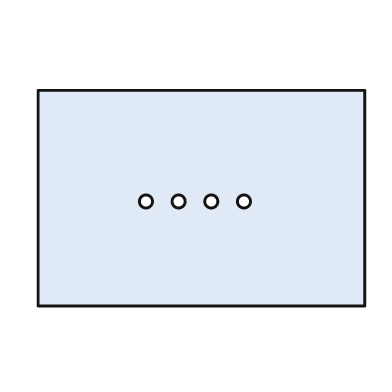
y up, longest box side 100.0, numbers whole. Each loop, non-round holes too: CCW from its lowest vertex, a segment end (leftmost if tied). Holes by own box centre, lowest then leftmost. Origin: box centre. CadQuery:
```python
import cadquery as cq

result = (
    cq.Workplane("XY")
    .moveTo(-50.0, -33.0)
    .lineTo(50.0, -33.0)
    .lineTo(50.0, 33.0)
    .lineTo(-50.0, 33.0)
    .close()
    .moveTo(-17.0, -1.0)
    .circle(2.0)
    .moveTo(-7.0, -1.0)
    .circle(2.0)
    .moveTo(3.0, -1.0)
    .circle(2.0)
    .moveTo(13.0, -1.0)
    .circle(2.0)
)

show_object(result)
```